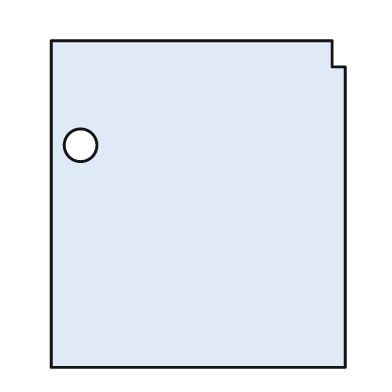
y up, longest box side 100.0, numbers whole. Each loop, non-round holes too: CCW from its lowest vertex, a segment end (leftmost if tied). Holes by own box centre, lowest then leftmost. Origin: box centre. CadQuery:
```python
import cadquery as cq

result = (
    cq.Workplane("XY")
    .moveTo(-45.0, -50.0)
    .lineTo(45.0, -50.0)
    .lineTo(45.0, 42.0)
    .lineTo(41.0, 42.0)
    .lineTo(41.0, 50.0)
    .lineTo(-45.0, 50.0)
    .close()
    .moveTo(-36.0, 18.0)
    .circle(5.0)
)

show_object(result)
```